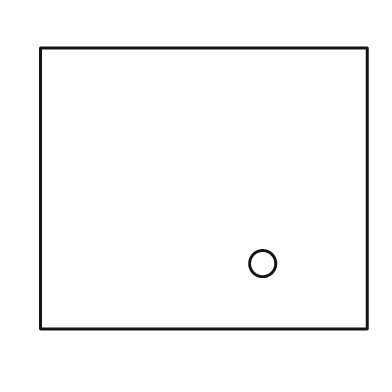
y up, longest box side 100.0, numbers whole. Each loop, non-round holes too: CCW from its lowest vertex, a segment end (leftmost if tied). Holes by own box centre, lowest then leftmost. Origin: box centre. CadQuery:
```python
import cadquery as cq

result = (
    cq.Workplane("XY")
    .moveTo(-50.0, -43.0)
    .lineTo(50.0, -43.0)
    .lineTo(50.0, 43.0)
    .lineTo(-50.0, 43.0)
    .close()
    .moveTo(18.0, -23.0)
    .circle(4.0)
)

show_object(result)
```